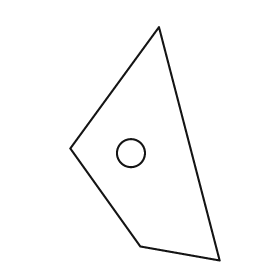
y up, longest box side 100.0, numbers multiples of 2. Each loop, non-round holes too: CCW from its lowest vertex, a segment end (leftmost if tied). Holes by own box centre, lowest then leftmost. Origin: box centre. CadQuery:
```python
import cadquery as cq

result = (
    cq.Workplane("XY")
    .moveTo(32.0, -50.0)
    .lineTo(6.0, 50.0)
    .lineTo(-32.0, -2.0)
    .lineTo(-2.0, -44.0)
    .close()
    .moveTo(-6.0, -4.0)
    .circle(6.0)
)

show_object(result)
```